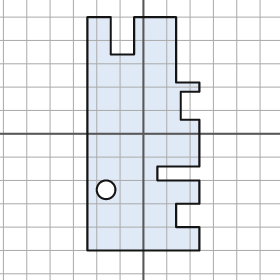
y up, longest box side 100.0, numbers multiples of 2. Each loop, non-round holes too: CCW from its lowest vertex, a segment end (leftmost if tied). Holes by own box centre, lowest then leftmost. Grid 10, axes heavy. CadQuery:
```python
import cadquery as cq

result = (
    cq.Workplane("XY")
    .moveTo(-24.0, -50.0)
    .lineTo(24.0, -50.0)
    .lineTo(24.0, -40.0)
    .lineTo(14.0, -40.0)
    .lineTo(14.0, -30.0)
    .lineTo(24.0, -30.0)
    .lineTo(24.0, -20.0)
    .lineTo(6.0, -20.0)
    .lineTo(6.0, -14.0)
    .lineTo(24.0, -14.0)
    .lineTo(24.0, 6.0)
    .lineTo(16.0, 6.0)
    .lineTo(16.0, 18.0)
    .lineTo(24.0, 18.0)
    .lineTo(24.0, 22.0)
    .lineTo(14.0, 22.0)
    .lineTo(14.0, 50.0)
    .lineTo(-4.0, 50.0)
    .lineTo(-4.0, 34.0)
    .lineTo(-14.0, 34.0)
    .lineTo(-14.0, 50.0)
    .lineTo(-24.0, 50.0)
    .close()
    .moveTo(-16.0, -24.0)
    .circle(4.0)
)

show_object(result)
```